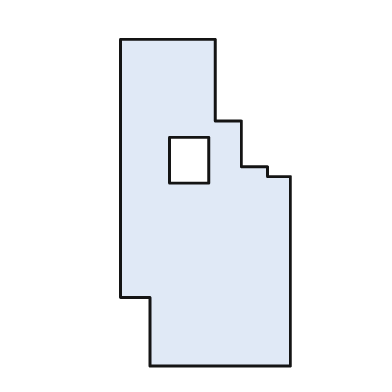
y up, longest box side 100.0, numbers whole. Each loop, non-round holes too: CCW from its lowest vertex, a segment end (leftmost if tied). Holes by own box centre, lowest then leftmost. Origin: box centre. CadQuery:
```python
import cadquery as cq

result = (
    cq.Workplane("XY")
    .moveTo(-17.0, -50.0)
    .lineTo(26.0, -50.0)
    .lineTo(26.0, 8.0)
    .lineTo(19.0, 8.0)
    .lineTo(19.0, 11.0)
    .lineTo(11.0, 11.0)
    .lineTo(11.0, 25.0)
    .lineTo(3.0, 25.0)
    .lineTo(3.0, 50.0)
    .lineTo(-26.0, 50.0)
    .lineTo(-26.0, -29.0)
    .lineTo(-17.0, -29.0)
    .close()
    .moveTo(-11.0, 6.0)
    .lineTo(1.0, 6.0)
    .lineTo(1.0, 20.0)
    .lineTo(-11.0, 20.0)
    .close()
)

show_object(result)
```